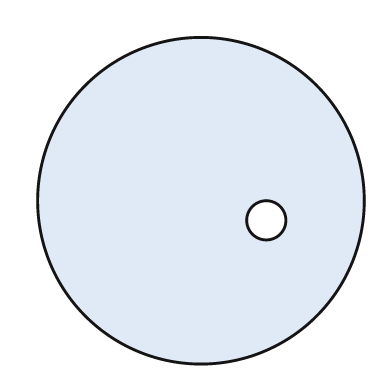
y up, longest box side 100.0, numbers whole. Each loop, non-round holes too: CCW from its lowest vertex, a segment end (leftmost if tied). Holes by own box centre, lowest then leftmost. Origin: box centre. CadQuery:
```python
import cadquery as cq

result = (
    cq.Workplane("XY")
    .moveTo(0.0, 0.0)
    .circle(50.0)
    .moveTo(20.0, -6.0)
    .circle(6.0)
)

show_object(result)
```